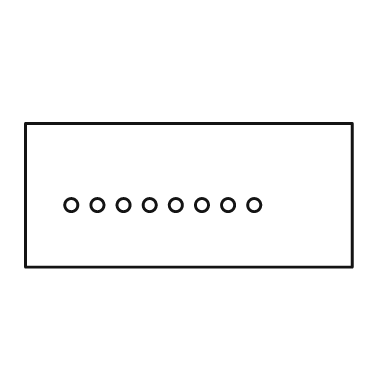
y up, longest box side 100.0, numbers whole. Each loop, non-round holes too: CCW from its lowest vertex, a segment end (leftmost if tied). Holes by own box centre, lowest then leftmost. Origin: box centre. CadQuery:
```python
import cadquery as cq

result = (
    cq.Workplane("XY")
    .moveTo(-50.0, -22.0)
    .lineTo(50.0, -22.0)
    .lineTo(50.0, 22.0)
    .lineTo(-50.0, 22.0)
    .close()
    .moveTo(-36.0, -3.0)
    .circle(2.0)
    .moveTo(-28.0, -3.0)
    .circle(2.0)
    .moveTo(-20.0, -3.0)
    .circle(2.0)
    .moveTo(-12.0, -3.0)
    .circle(2.0)
    .moveTo(-4.0, -3.0)
    .circle(2.0)
    .moveTo(4.0, -3.0)
    .circle(2.0)
    .moveTo(12.0, -3.0)
    .circle(2.0)
    .moveTo(20.0, -3.0)
    .circle(2.0)
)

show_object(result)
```